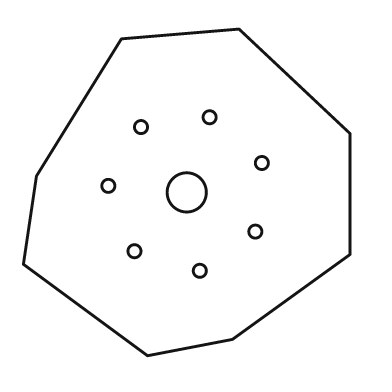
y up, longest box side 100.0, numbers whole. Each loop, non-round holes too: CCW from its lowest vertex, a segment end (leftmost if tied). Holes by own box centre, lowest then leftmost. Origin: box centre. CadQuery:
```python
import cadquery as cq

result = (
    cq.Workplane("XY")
    .moveTo(-12.0, -50.0)
    .lineTo(14.0, -45.0)
    .lineTo(50.0, -19.0)
    .lineTo(50.0, 18.0)
    .lineTo(16.0, 50.0)
    .lineTo(-20.0, 47.0)
    .lineTo(-46.0, 5.0)
    .lineTo(-50.0, -22.0)
    .close()
    .moveTo(4.0, -24.0)
    .circle(2.0)
    .moveTo(-16.0, -18.0)
    .circle(2.0)
    .moveTo(21.0, -12.0)
    .circle(2.0)
    .moveTo(0.0, 0.0)
    .circle(6.0)
    .moveTo(-24.0, 2.0)
    .circle(2.0)
    .moveTo(23.0, 9.0)
    .circle(2.0)
    .moveTo(-14.0, 20.0)
    .circle(2.0)
    .moveTo(7.0, 23.0)
    .circle(2.0)
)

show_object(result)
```